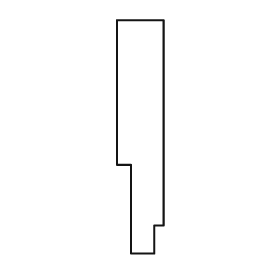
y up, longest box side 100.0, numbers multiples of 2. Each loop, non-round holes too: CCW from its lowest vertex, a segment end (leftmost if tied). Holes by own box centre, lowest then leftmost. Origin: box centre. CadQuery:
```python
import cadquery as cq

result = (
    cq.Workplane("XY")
    .moveTo(-4.0, -50.0)
    .lineTo(6.0, -50.0)
    .lineTo(6.0, -38.0)
    .lineTo(10.0, -38.0)
    .lineTo(10.0, 50.0)
    .lineTo(-10.0, 50.0)
    .lineTo(-10.0, -12.0)
    .lineTo(-4.0, -12.0)
    .close()
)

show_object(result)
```